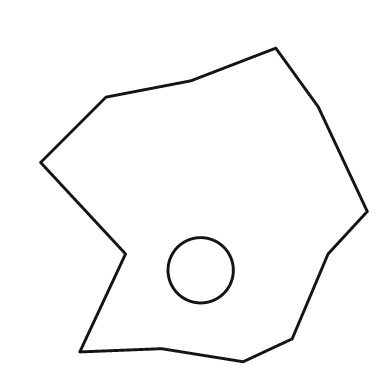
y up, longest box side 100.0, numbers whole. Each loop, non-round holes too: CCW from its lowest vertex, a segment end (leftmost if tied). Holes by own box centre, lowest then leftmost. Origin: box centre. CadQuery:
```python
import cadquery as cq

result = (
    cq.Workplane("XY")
    .moveTo(12.0, -48.0)
    .lineTo(27.0, -41.0)
    .lineTo(38.0, -15.0)
    .lineTo(50.0, -2.0)
    .lineTo(35.0, 30.0)
    .lineTo(22.0, 48.0)
    .lineTo(-4.0, 38.0)
    .lineTo(-30.0, 33.0)
    .lineTo(-50.0, 13.0)
    .lineTo(-24.0, -15.0)
    .lineTo(-38.0, -45.0)
    .lineTo(-13.0, -44.0)
    .close()
    .moveTo(-1.0, -20.0)
    .circle(10.0)
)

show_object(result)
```